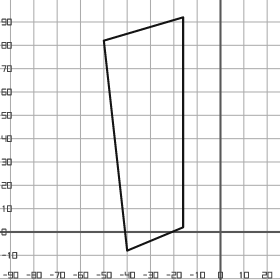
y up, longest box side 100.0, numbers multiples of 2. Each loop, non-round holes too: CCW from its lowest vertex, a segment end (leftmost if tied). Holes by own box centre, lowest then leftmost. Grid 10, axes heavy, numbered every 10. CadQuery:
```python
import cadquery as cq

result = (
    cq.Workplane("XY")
    .moveTo(-40.0, -8.0)
    .lineTo(-16.0, 2.0)
    .lineTo(-16.0, 92.0)
    .lineTo(-50.0, 82.0)
    .close()
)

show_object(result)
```